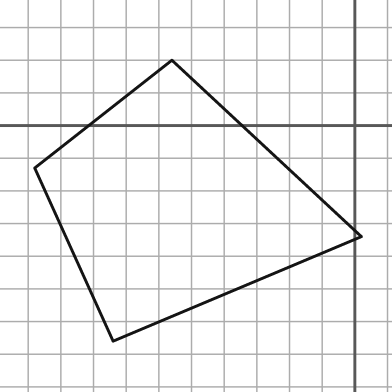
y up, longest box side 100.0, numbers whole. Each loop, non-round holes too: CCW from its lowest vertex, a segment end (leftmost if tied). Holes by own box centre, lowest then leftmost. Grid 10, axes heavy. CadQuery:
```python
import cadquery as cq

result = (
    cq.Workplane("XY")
    .moveTo(-74.0, -66.0)
    .lineTo(2.0, -34.0)
    .lineTo(-56.0, 20.0)
    .lineTo(-98.0, -13.0)
    .close()
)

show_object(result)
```